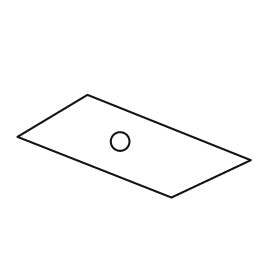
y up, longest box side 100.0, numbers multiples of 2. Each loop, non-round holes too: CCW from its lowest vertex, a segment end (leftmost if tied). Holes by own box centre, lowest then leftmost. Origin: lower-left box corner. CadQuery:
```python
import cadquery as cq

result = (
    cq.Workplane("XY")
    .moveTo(66.0, 0.0)
    .lineTo(100.0, 16.0)
    .lineTo(30.0, 44.0)
    .lineTo(0.0, 26.0)
    .close()
    .moveTo(44.0, 24.0)
    .circle(4.0)
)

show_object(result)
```